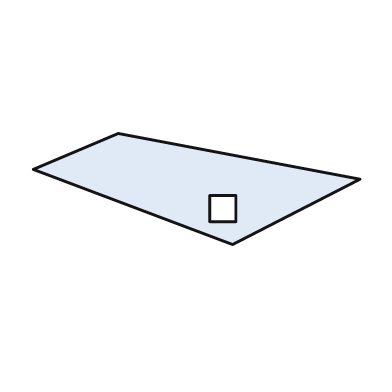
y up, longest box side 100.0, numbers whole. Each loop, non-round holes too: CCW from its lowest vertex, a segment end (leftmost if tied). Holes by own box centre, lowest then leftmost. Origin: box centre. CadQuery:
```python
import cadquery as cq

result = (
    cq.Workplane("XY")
    .moveTo(11.0, -17.0)
    .lineTo(50.0, 3.0)
    .lineTo(-24.0, 17.0)
    .lineTo(-50.0, 6.0)
    .close()
    .moveTo(4.0, -10.0)
    .lineTo(12.0, -10.0)
    .lineTo(12.0, -2.0)
    .lineTo(4.0, -2.0)
    .close()
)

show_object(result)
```